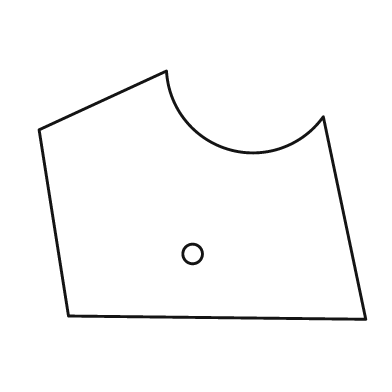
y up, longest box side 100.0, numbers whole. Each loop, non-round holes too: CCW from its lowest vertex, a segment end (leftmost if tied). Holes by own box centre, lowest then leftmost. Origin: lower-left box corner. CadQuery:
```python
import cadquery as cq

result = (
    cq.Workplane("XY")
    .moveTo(100.0, 0.0)
    .lineTo(87.0, 62.0)
    .threePointArc((58.0, 52.0), (39.0, 76.0))
    .lineTo(0.0, 58.0)
    .lineTo(9.0, 1.0)
    .close()
    .moveTo(47.0, 20.0)
    .circle(3.0)
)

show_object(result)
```